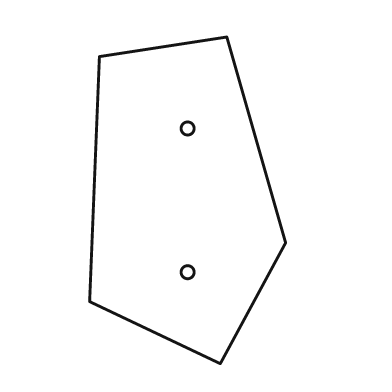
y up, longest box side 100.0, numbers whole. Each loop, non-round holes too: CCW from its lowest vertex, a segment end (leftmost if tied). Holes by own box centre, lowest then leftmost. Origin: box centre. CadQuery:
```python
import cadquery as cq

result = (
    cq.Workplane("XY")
    .moveTo(10.0, -50.0)
    .lineTo(30.0, -13.0)
    .lineTo(12.0, 50.0)
    .lineTo(-27.0, 44.0)
    .lineTo(-30.0, -31.0)
    .close()
    .moveTo(0.0, -22.0)
    .circle(2.0)
    .moveTo(0.0, 22.0)
    .circle(2.0)
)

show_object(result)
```